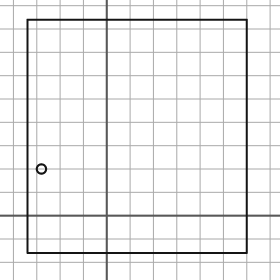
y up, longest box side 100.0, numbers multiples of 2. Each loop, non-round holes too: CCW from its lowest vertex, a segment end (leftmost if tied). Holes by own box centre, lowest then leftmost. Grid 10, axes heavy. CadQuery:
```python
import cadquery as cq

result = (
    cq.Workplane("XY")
    .moveTo(-34.0, -16.0)
    .lineTo(60.0, -16.0)
    .lineTo(60.0, 84.0)
    .lineTo(-34.0, 84.0)
    .close()
    .moveTo(-28.0, 20.0)
    .circle(2.0)
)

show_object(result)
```